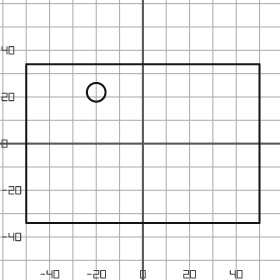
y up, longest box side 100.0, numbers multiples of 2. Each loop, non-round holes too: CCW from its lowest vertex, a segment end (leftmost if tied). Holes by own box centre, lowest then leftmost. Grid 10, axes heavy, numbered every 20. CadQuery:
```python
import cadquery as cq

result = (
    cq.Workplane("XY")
    .moveTo(-50.0, -34.0)
    .lineTo(50.0, -34.0)
    .lineTo(50.0, 34.0)
    .lineTo(-50.0, 34.0)
    .close()
    .moveTo(-20.0, 22.0)
    .circle(4.0)
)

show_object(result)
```